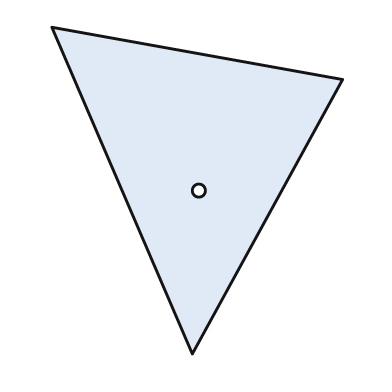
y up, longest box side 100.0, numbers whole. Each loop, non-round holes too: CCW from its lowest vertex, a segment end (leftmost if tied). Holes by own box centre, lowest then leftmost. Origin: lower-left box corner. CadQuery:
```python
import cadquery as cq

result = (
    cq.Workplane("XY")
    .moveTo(43.0, 0.0)
    .lineTo(89.0, 84.0)
    .lineTo(0.0, 100.0)
    .close()
    .moveTo(45.0, 50.0)
    .circle(2.0)
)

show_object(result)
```